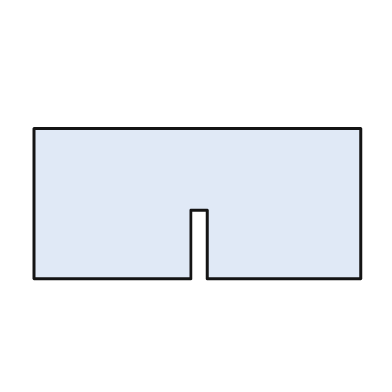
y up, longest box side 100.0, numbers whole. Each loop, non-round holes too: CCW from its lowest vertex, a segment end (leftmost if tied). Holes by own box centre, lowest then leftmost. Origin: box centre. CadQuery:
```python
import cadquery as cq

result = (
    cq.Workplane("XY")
    .moveTo(-50.0, -23.0)
    .lineTo(-2.0, -23.0)
    .lineTo(-2.0, -2.0)
    .lineTo(3.0, -2.0)
    .lineTo(3.0, -23.0)
    .lineTo(50.0, -23.0)
    .lineTo(50.0, 23.0)
    .lineTo(-50.0, 23.0)
    .close()
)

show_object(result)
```